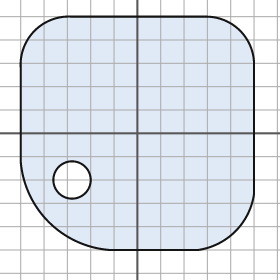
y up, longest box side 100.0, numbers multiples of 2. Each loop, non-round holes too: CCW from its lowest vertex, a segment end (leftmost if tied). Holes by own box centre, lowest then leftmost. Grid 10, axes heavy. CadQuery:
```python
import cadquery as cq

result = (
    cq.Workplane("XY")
    .moveTo(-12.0, -50.0)
    .lineTo(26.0, -50.0)
    .threePointArc((42.0, -42.0), (50.0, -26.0))
    .lineTo(50.0, 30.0)
    .threePointArc((44.0, 44.0), (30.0, 50.0))
    .lineTo(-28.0, 50.0)
    .threePointArc((-44.0, 44.0), (-50.0, 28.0))
    .lineTo(-50.0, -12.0)
    .threePointArc((-38.0, -38.0), (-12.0, -50.0))
    .close()
    .moveTo(-28.0, -20.0)
    .circle(8.0)
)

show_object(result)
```